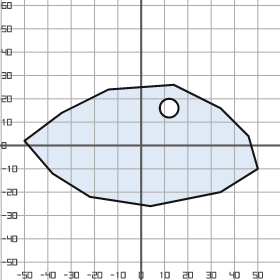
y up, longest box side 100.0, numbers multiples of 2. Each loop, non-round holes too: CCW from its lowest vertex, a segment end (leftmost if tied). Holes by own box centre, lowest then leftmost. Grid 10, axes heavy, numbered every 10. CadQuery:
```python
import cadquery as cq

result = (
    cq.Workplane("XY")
    .moveTo(4.0, -26.0)
    .lineTo(34.0, -20.0)
    .lineTo(50.0, -10.0)
    .lineTo(46.0, 4.0)
    .lineTo(34.0, 16.0)
    .lineTo(14.0, 26.0)
    .lineTo(-14.0, 24.0)
    .lineTo(-34.0, 14.0)
    .lineTo(-50.0, 2.0)
    .lineTo(-38.0, -12.0)
    .lineTo(-22.0, -22.0)
    .close()
    .moveTo(12.0, 16.0)
    .circle(4.0)
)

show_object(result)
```